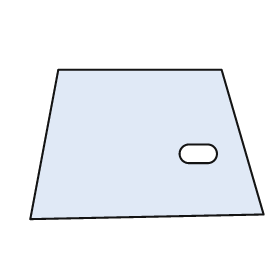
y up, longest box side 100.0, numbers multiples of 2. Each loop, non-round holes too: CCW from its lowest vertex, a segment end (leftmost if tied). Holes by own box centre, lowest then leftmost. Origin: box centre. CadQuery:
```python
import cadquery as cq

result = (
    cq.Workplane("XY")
    .moveTo(-50.0, -32.0)
    .lineTo(50.0, -30.0)
    .lineTo(32.0, 32.0)
    .lineTo(-38.0, 32.0)
    .close()
    .moveTo(18.0, -8.0)
    .lineTo(26.0, -8.0)
    .threePointArc((30.0, -4.0), (26.0, 0.0))
    .lineTo(18.0, 0.0)
    .threePointArc((14.0, -4.0), (18.0, -8.0))
    .close()
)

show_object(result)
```